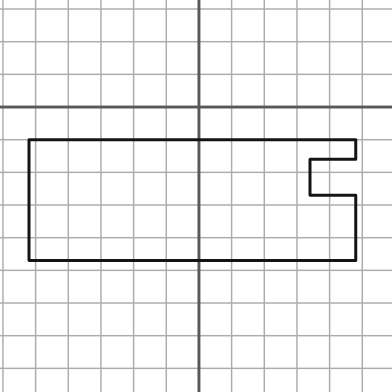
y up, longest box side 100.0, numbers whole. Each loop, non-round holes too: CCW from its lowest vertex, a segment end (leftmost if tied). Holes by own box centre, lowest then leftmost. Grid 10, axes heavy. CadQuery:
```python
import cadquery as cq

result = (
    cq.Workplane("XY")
    .moveTo(-52.0, -47.0)
    .lineTo(48.0, -47.0)
    .lineTo(48.0, -27.0)
    .lineTo(34.0, -27.0)
    .lineTo(34.0, -16.0)
    .lineTo(48.0, -16.0)
    .lineTo(48.0, -10.0)
    .lineTo(-52.0, -10.0)
    .close()
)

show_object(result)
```